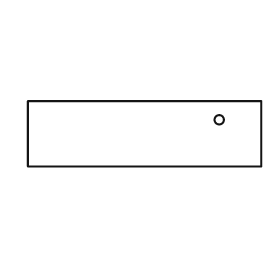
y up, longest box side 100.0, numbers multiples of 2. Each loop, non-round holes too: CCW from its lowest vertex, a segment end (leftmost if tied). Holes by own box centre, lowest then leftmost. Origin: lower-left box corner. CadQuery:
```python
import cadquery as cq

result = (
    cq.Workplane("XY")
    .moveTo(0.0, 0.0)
    .lineTo(100.0, 0.0)
    .lineTo(100.0, 28.0)
    .lineTo(0.0, 28.0)
    .close()
    .moveTo(82.0, 20.0)
    .circle(2.0)
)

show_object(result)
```